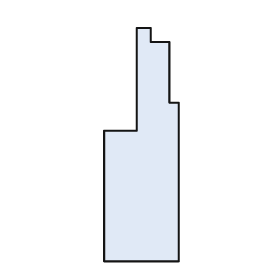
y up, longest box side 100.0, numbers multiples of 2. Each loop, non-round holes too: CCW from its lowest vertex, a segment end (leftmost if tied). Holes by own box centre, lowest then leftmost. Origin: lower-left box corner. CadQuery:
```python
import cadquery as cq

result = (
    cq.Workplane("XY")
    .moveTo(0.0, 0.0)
    .lineTo(32.0, 0.0)
    .lineTo(32.0, 68.0)
    .lineTo(28.0, 68.0)
    .lineTo(28.0, 94.0)
    .lineTo(20.0, 94.0)
    .lineTo(20.0, 100.0)
    .lineTo(14.0, 100.0)
    .lineTo(14.0, 56.0)
    .lineTo(0.0, 56.0)
    .close()
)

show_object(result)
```